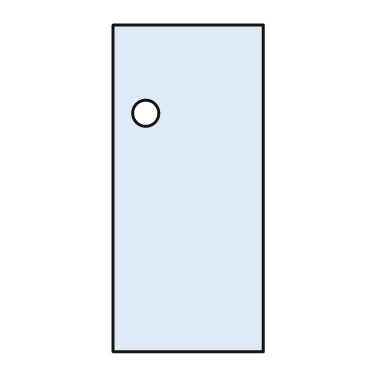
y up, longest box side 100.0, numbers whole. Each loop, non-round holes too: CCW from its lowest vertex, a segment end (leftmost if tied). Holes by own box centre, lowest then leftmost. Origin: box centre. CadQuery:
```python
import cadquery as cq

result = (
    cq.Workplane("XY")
    .moveTo(-23.0, -50.0)
    .lineTo(23.0, -50.0)
    .lineTo(23.0, 50.0)
    .lineTo(-23.0, 50.0)
    .close()
    .moveTo(-13.0, 23.0)
    .circle(4.0)
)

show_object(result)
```